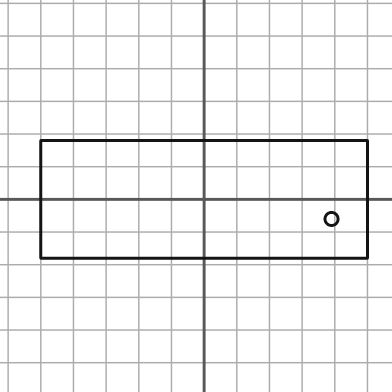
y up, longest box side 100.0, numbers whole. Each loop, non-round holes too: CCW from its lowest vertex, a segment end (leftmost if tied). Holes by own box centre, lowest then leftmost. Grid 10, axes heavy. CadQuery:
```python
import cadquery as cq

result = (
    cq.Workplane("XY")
    .moveTo(-50.0, -18.0)
    .lineTo(50.0, -18.0)
    .lineTo(50.0, 18.0)
    .lineTo(-50.0, 18.0)
    .close()
    .moveTo(39.0, -6.0)
    .circle(2.0)
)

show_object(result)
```